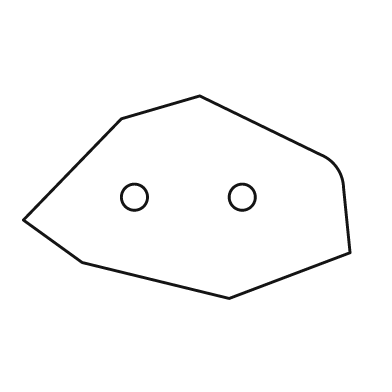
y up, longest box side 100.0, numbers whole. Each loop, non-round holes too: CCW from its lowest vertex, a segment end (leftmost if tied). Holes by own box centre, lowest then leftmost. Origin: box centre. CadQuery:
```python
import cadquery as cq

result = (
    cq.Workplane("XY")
    .moveTo(13.0, -31.0)
    .lineTo(50.0, -17.0)
    .lineTo(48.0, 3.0)
    .threePointArc((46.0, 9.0), (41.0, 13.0))
    .lineTo(4.0, 31.0)
    .lineTo(-20.0, 24.0)
    .lineTo(-50.0, -7.0)
    .lineTo(-32.0, -20.0)
    .close()
    .moveTo(-16.0, 0.0)
    .circle(4.0)
    .moveTo(17.0, 0.0)
    .circle(4.0)
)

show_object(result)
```